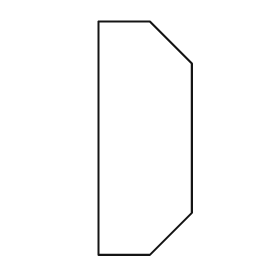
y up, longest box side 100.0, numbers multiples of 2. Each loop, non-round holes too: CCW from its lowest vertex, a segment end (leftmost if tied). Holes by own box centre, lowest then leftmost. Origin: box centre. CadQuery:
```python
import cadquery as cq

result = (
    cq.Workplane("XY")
    .moveTo(-20.0, -50.0)
    .lineTo(2.0, -50.0)
    .lineTo(20.0, -32.0)
    .lineTo(20.0, 32.0)
    .lineTo(2.0, 50.0)
    .lineTo(-20.0, 50.0)
    .close()
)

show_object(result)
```